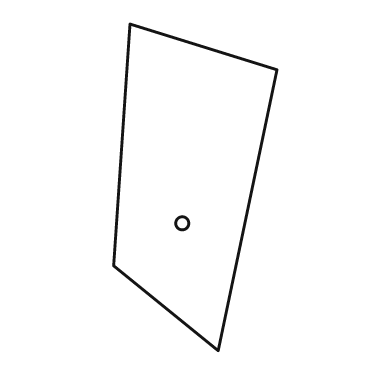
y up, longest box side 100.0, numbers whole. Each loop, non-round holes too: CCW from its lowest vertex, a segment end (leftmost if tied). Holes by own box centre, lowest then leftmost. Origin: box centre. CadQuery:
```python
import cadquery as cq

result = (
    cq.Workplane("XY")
    .moveTo(7.0, -50.0)
    .lineTo(25.0, 36.0)
    .lineTo(-20.0, 50.0)
    .lineTo(-25.0, -24.0)
    .close()
    .moveTo(-4.0, -11.0)
    .circle(2.0)
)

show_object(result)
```